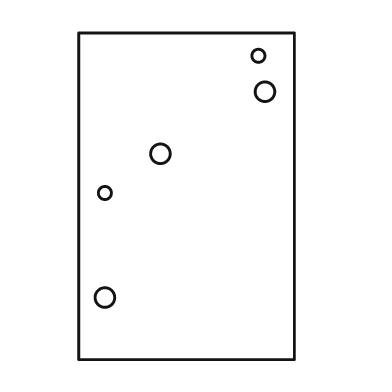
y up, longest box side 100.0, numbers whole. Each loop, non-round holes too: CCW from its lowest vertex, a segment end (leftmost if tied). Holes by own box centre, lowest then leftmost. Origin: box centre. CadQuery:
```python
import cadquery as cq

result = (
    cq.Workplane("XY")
    .moveTo(-33.0, -50.0)
    .lineTo(33.0, -50.0)
    .lineTo(33.0, 50.0)
    .lineTo(-33.0, 50.0)
    .close()
    .moveTo(-25.0, -31.0)
    .circle(3.0)
    .moveTo(-25.0, 1.0)
    .circle(2.0)
    .moveTo(-8.0, 13.0)
    .circle(3.0)
    .moveTo(24.0, 32.0)
    .circle(3.0)
    .moveTo(22.0, 43.0)
    .circle(2.0)
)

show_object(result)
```